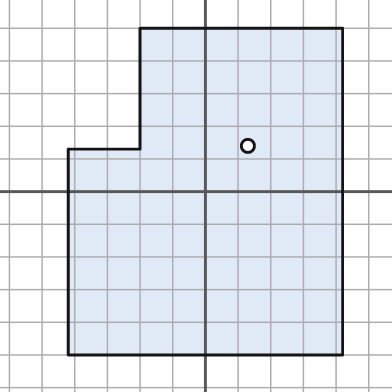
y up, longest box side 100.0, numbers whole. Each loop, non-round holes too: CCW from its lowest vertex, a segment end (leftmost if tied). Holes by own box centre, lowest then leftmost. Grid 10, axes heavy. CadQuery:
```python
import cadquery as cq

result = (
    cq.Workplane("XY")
    .moveTo(-42.0, -50.0)
    .lineTo(42.0, -50.0)
    .lineTo(42.0, 50.0)
    .lineTo(-20.0, 50.0)
    .lineTo(-20.0, 13.0)
    .lineTo(-42.0, 13.0)
    .close()
    .moveTo(13.0, 14.0)
    .circle(2.0)
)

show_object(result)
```